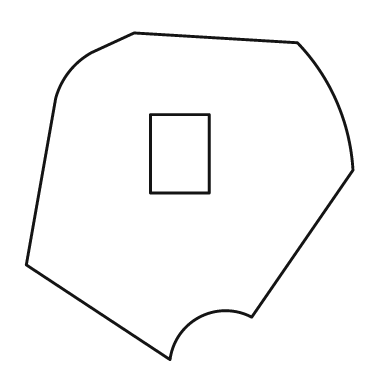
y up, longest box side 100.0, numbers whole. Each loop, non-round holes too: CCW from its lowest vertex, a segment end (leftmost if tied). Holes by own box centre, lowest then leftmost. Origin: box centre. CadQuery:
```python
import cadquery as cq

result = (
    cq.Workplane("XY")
    .moveTo(-6.0, -50.0)
    .threePointArc((3.0, -37.0), (19.0, -37.0))
    .lineTo(50.0, 8.0)
    .threePointArc((45.0, 29.0), (33.0, 47.0))
    .lineTo(-17.0, 50.0)
    .lineTo(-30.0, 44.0)
    .threePointArc((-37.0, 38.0), (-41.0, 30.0))
    .lineTo(-50.0, -21.0)
    .close()
    .moveTo(-12.0, 1.0)
    .lineTo(6.0, 1.0)
    .lineTo(6.0, 25.0)
    .lineTo(-12.0, 25.0)
    .close()
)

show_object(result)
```